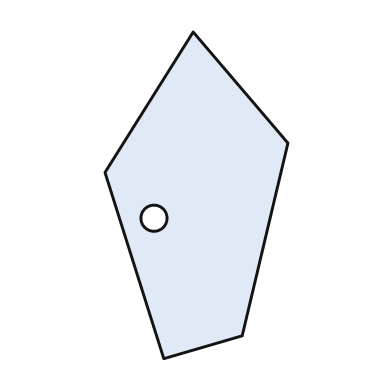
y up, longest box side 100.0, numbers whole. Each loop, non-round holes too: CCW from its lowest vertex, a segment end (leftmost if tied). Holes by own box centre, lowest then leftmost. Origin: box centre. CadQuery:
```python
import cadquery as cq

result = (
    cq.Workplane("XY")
    .moveTo(-10.0, -50.0)
    .lineTo(14.0, -43.0)
    .lineTo(28.0, 16.0)
    .lineTo(-1.0, 50.0)
    .lineTo(-28.0, 7.0)
    .close()
    .moveTo(-13.0, -7.0)
    .circle(4.0)
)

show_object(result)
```